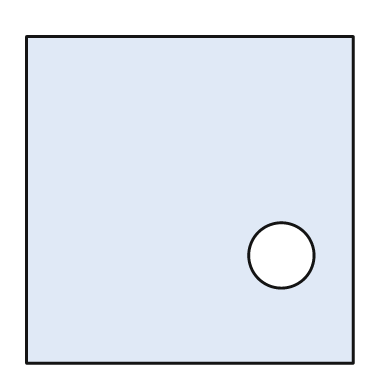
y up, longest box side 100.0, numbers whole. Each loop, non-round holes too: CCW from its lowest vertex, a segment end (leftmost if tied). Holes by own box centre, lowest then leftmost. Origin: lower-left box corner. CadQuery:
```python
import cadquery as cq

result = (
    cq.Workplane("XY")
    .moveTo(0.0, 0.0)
    .lineTo(100.0, 0.0)
    .lineTo(100.0, 100.0)
    .lineTo(0.0, 100.0)
    .close()
    .moveTo(78.0, 33.0)
    .circle(10.0)
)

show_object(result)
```